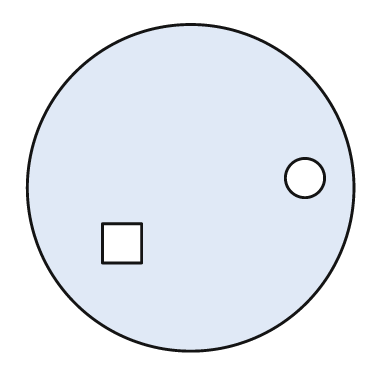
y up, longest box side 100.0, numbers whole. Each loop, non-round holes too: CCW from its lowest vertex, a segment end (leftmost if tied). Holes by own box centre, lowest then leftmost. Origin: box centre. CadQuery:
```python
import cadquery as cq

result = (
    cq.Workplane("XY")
    .moveTo(0.0, 0.0)
    .circle(50.0)
    .moveTo(-27.0, -23.0)
    .lineTo(-15.0, -23.0)
    .lineTo(-15.0, -11.0)
    .lineTo(-27.0, -11.0)
    .close()
    .moveTo(35.0, 3.0)
    .circle(6.0)
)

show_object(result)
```